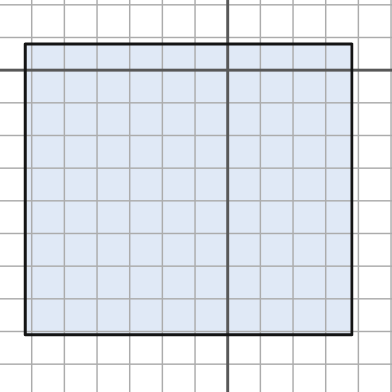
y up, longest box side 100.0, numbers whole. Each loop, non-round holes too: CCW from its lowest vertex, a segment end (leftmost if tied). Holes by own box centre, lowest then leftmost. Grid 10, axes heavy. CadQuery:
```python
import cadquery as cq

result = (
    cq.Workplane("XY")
    .moveTo(-62.0, -81.0)
    .lineTo(38.0, -81.0)
    .lineTo(38.0, 8.0)
    .lineTo(-62.0, 8.0)
    .close()
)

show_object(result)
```